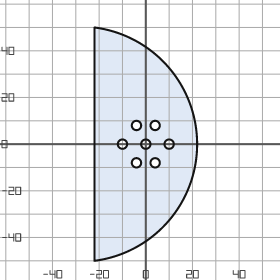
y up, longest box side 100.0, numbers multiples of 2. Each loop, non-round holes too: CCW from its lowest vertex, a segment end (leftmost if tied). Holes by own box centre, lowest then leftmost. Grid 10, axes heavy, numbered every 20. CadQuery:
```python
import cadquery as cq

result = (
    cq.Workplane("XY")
    .moveTo(-22.0, -50.0)
    .threePointArc((22.0, 0.0), (-22.0, 50.0))
    .close()
    .moveTo(-4.0, -8.0)
    .circle(2.0)
    .moveTo(4.0, -8.0)
    .circle(2.0)
    .moveTo(-10.0, 0.0)
    .circle(2.0)
    .moveTo(0.0, 0.0)
    .circle(2.0)
    .moveTo(10.0, 0.0)
    .circle(2.0)
    .moveTo(-4.0, 8.0)
    .circle(2.0)
    .moveTo(4.0, 8.0)
    .circle(2.0)
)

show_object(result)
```